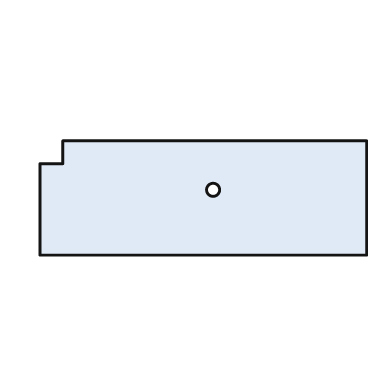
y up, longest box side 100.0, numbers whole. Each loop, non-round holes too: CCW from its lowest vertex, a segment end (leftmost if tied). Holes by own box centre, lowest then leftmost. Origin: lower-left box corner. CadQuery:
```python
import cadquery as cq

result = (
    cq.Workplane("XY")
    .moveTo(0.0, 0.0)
    .lineTo(100.0, 0.0)
    .lineTo(100.0, 35.0)
    .lineTo(7.0, 35.0)
    .lineTo(7.0, 28.0)
    .lineTo(0.0, 28.0)
    .close()
    .moveTo(53.0, 20.0)
    .circle(2.0)
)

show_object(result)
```